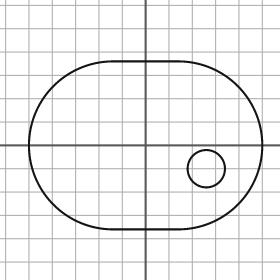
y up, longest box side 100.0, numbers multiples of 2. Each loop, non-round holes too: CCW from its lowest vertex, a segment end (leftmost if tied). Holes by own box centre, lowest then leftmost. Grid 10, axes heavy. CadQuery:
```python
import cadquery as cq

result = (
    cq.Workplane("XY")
    .moveTo(-14.0, -36.0)
    .lineTo(14.0, -36.0)
    .threePointArc((50.0, 0.0), (14.0, 36.0))
    .lineTo(-14.0, 36.0)
    .threePointArc((-50.0, 0.0), (-14.0, -36.0))
    .close()
    .moveTo(26.0, -10.0)
    .circle(8.0)
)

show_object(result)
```